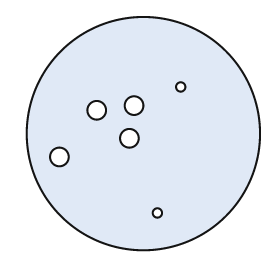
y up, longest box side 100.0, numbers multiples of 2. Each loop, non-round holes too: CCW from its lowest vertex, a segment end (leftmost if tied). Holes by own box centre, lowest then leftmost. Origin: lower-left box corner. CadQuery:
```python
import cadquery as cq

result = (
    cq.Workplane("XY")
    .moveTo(50.0, 50.0)
    .circle(50.0)
    .moveTo(56.0, 16.0)
    .circle(2.0)
    .moveTo(14.0, 40.0)
    .circle(4.0)
    .moveTo(44.0, 48.0)
    .circle(4.0)
    .moveTo(30.0, 60.0)
    .circle(4.0)
    .moveTo(46.0, 62.0)
    .circle(4.0)
    .moveTo(66.0, 70.0)
    .circle(2.0)
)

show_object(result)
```